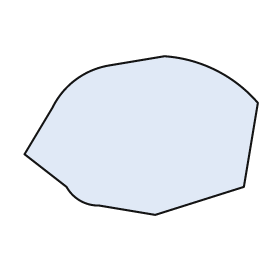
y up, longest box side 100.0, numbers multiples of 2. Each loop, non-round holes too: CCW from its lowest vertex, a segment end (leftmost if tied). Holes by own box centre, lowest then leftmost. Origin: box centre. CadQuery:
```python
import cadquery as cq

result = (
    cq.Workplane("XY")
    .moveTo(6.0, -34.0)
    .lineTo(44.0, -22.0)
    .lineTo(50.0, 14.0)
    .threePointArc((32.0, 28.0), (10.0, 34.0))
    .lineTo(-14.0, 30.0)
    .threePointArc((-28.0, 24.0), (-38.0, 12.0))
    .lineTo(-50.0, -8.0)
    .lineTo(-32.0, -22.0)
    .threePointArc((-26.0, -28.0), (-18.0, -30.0))
    .close()
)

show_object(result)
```